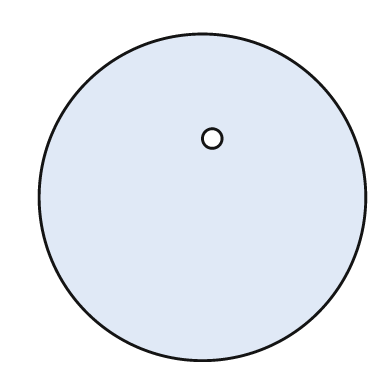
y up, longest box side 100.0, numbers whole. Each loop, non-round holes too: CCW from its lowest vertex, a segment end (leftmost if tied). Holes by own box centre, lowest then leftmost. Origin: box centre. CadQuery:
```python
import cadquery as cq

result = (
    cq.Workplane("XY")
    .moveTo(0.0, 0.0)
    .circle(50.0)
    .moveTo(3.0, 18.0)
    .circle(3.0)
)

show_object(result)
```